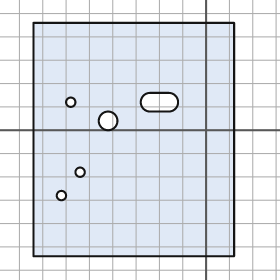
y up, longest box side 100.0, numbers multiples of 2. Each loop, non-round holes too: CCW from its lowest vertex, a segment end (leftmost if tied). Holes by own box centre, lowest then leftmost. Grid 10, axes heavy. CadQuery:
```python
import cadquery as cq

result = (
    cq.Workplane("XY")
    .moveTo(-74.0, -54.0)
    .lineTo(12.0, -54.0)
    .lineTo(12.0, 46.0)
    .lineTo(-74.0, 46.0)
    .close()
    .moveTo(-62.0, -28.0)
    .circle(2.0)
    .moveTo(-54.0, -18.0)
    .circle(2.0)
    .moveTo(-42.0, 4.0)
    .circle(4.0)
    .moveTo(-58.0, 12.0)
    .circle(2.0)
    .moveTo(-24.0, 8.0)
    .lineTo(-16.0, 8.0)
    .threePointArc((-12.0, 12.0), (-16.0, 16.0))
    .lineTo(-24.0, 16.0)
    .threePointArc((-28.0, 12.0), (-24.0, 8.0))
    .close()
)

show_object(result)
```